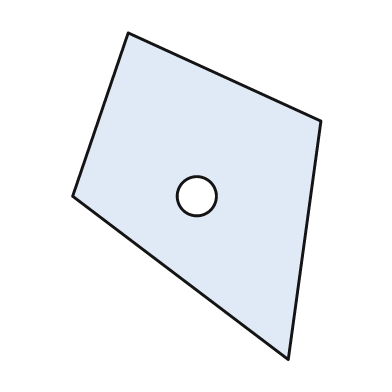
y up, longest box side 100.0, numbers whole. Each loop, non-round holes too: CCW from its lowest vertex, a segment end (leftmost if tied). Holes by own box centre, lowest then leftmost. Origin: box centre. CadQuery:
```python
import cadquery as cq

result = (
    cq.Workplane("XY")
    .moveTo(28.0, -50.0)
    .lineTo(38.0, 23.0)
    .lineTo(-21.0, 50.0)
    .lineTo(-38.0, 0.0)
    .close()
    .moveTo(0.0, 0.0)
    .circle(6.0)
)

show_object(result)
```